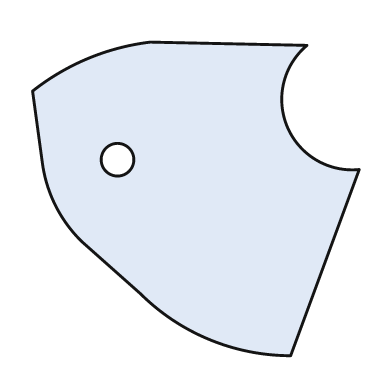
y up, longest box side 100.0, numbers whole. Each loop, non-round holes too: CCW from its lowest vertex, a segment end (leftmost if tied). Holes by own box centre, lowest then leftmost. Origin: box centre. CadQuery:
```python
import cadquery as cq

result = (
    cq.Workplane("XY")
    .moveTo(29.0, -48.0)
    .lineTo(50.0, 9.0)
    .threePointArc((28.0, 22.0), (34.0, 47.0))
    .lineTo(-14.0, 48.0)
    .threePointArc((-33.0, 43.0), (-50.0, 33.0))
    .lineTo(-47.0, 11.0)
    .threePointArc((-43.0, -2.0), (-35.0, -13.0))
    .lineTo(-17.0, -29.0)
    .threePointArc((4.0, -43.0), (29.0, -48.0))
    .close()
    .moveTo(-24.0, 12.0)
    .circle(5.0)
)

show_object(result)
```